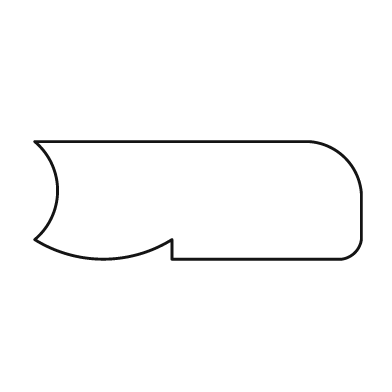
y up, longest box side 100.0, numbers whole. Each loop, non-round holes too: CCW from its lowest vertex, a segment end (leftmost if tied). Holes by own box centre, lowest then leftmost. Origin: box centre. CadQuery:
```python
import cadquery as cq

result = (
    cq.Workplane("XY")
    .moveTo(-8.0, -18.0)
    .lineTo(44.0, -18.0)
    .threePointArc((48.0, -16.0), (50.0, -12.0))
    .lineTo(50.0, 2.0)
    .threePointArc((45.0, 13.0), (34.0, 18.0))
    .lineTo(-50.0, 18.0)
    .threePointArc((-43.0, 3.0), (-50.0, -12.0))
    .threePointArc((-29.0, -18.0), (-8.0, -12.0))
    .close()
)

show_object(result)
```